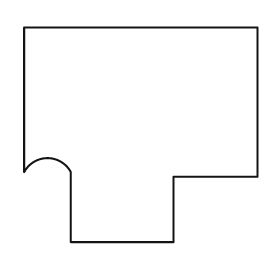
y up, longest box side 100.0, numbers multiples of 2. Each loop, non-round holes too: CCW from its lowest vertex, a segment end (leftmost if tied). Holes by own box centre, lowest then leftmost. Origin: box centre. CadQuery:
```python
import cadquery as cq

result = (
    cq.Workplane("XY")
    .moveTo(-30.0, -46.0)
    .lineTo(14.0, -46.0)
    .lineTo(14.0, -18.0)
    .lineTo(50.0, -18.0)
    .lineTo(50.0, 46.0)
    .lineTo(-50.0, 46.0)
    .lineTo(-50.0, -16.0)
    .threePointArc((-40.0, -10.0), (-30.0, -16.0))
    .close()
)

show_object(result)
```